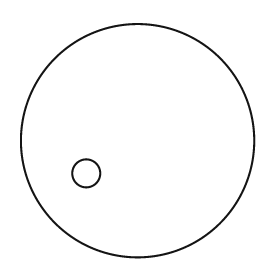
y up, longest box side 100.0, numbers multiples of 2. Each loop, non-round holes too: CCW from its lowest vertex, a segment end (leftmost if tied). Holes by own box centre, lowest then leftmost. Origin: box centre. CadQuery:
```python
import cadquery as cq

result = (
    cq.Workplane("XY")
    .moveTo(0.0, 0.0)
    .circle(50.0)
    .moveTo(-22.0, -14.0)
    .circle(6.0)
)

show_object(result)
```